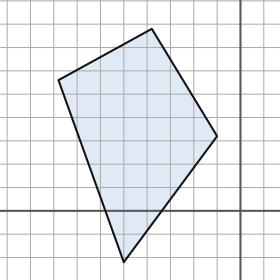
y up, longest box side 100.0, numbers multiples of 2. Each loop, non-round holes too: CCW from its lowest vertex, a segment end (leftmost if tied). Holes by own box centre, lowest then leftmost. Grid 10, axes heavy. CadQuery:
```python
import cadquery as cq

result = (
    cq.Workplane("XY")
    .moveTo(-50.0, -22.0)
    .lineTo(-10.0, 32.0)
    .lineTo(-38.0, 78.0)
    .lineTo(-78.0, 56.0)
    .close()
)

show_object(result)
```